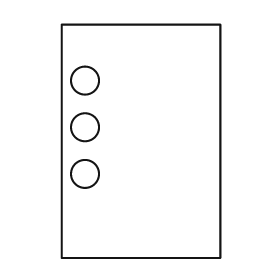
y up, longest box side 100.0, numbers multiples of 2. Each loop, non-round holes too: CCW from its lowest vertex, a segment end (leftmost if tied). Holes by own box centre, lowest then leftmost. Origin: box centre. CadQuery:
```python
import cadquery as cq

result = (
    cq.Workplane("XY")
    .moveTo(-34.0, -50.0)
    .lineTo(34.0, -50.0)
    .lineTo(34.0, 50.0)
    .lineTo(-34.0, 50.0)
    .close()
    .moveTo(-24.0, -14.0)
    .circle(6.0)
    .moveTo(-24.0, 6.0)
    .circle(6.0)
    .moveTo(-24.0, 26.0)
    .circle(6.0)
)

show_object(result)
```